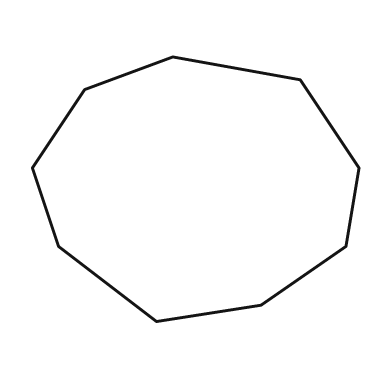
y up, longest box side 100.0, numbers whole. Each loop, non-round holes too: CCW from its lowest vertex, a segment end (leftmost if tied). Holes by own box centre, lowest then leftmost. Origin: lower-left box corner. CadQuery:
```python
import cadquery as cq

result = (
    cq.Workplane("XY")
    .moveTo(38.0, 0.0)
    .lineTo(70.0, 5.0)
    .lineTo(96.0, 23.0)
    .lineTo(100.0, 47.0)
    .lineTo(82.0, 74.0)
    .lineTo(43.0, 81.0)
    .lineTo(16.0, 71.0)
    .lineTo(0.0, 47.0)
    .lineTo(8.0, 23.0)
    .close()
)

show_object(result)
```